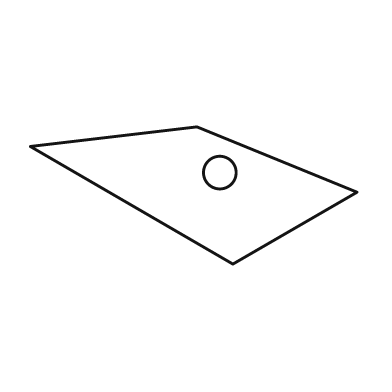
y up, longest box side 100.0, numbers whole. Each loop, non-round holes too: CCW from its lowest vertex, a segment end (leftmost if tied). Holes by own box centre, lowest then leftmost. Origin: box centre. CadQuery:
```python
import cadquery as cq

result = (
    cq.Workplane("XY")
    .moveTo(12.0, -21.0)
    .lineTo(50.0, 1.0)
    .lineTo(1.0, 21.0)
    .lineTo(-50.0, 15.0)
    .close()
    .moveTo(8.0, 7.0)
    .circle(5.0)
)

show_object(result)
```